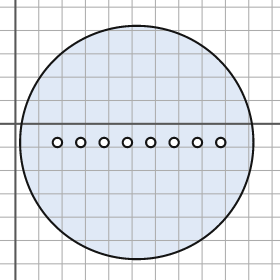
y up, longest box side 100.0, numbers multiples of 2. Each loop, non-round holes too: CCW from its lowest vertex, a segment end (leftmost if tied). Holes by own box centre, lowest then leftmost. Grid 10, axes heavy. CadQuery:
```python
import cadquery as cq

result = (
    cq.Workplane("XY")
    .moveTo(52.0, -8.0)
    .circle(50.0)
    .moveTo(18.0, -8.0)
    .circle(2.0)
    .moveTo(28.0, -8.0)
    .circle(2.0)
    .moveTo(38.0, -8.0)
    .circle(2.0)
    .moveTo(48.0, -8.0)
    .circle(2.0)
    .moveTo(58.0, -8.0)
    .circle(2.0)
    .moveTo(68.0, -8.0)
    .circle(2.0)
    .moveTo(78.0, -8.0)
    .circle(2.0)
    .moveTo(88.0, -8.0)
    .circle(2.0)
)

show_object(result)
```